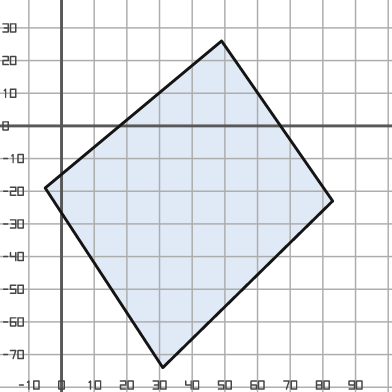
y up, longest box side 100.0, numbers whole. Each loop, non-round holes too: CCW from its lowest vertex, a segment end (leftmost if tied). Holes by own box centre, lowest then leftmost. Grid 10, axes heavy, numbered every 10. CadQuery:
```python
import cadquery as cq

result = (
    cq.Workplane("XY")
    .moveTo(31.0, -74.0)
    .lineTo(83.0, -23.0)
    .lineTo(49.0, 26.0)
    .lineTo(-5.0, -19.0)
    .close()
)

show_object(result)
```